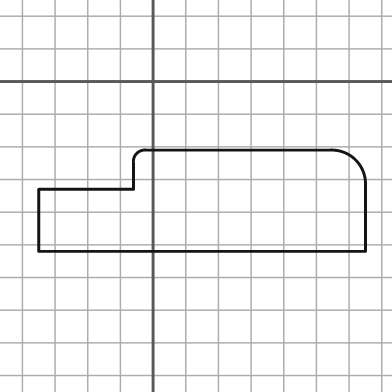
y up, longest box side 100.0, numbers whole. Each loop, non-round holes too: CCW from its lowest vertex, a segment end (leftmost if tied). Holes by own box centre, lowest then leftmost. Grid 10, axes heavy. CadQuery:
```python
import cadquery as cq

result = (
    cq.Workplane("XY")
    .moveTo(-35.0, -52.0)
    .lineTo(65.0, -52.0)
    .lineTo(65.0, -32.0)
    .threePointArc((62.0, -24.0), (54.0, -21.0))
    .lineTo(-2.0, -21.0)
    .threePointArc((-5.0, -22.0), (-6.0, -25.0))
    .lineTo(-6.0, -33.0)
    .lineTo(-35.0, -33.0)
    .close()
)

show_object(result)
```